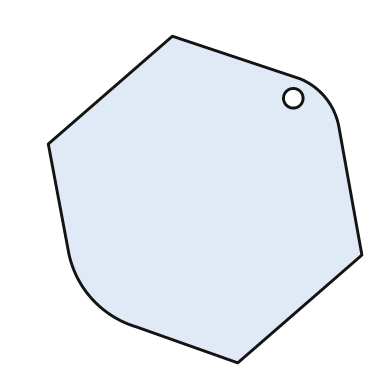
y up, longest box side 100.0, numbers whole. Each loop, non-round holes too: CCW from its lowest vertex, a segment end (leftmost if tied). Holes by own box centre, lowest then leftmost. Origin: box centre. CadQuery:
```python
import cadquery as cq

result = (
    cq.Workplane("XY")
    .moveTo(10.0, -50.0)
    .lineTo(48.0, -17.0)
    .lineTo(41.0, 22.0)
    .threePointArc((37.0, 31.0), (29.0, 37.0))
    .lineTo(-10.0, 50.0)
    .lineTo(-48.0, 17.0)
    .lineTo(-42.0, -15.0)
    .threePointArc((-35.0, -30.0), (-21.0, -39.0))
    .close()
    .moveTo(27.0, 31.0)
    .circle(3.0)
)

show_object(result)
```